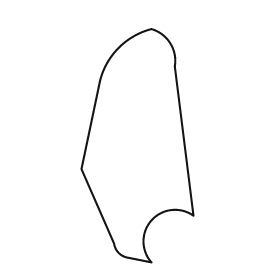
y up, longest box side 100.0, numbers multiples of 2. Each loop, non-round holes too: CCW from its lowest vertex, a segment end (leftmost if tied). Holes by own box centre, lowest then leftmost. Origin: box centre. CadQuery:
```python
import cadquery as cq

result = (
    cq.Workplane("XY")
    .moveTo(6.0, -50.0)
    .threePointArc((6.0, -32.0), (24.0, -30.0))
    .lineTo(16.0, 34.0)
    .threePointArc((14.0, 44.0), (6.0, 50.0))
    .threePointArc((-8.0, 42.0), (-16.0, 28.0))
    .lineTo(-24.0, -10.0)
    .lineTo(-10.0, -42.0)
    .threePointArc((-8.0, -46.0), (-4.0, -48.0))
    .close()
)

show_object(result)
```